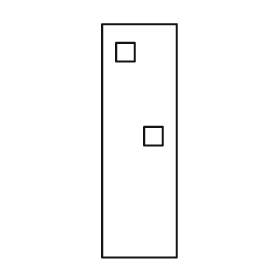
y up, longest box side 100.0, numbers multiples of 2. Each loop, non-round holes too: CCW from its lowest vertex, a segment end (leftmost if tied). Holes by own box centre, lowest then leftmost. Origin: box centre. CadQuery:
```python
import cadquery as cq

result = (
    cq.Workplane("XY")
    .moveTo(-16.0, -50.0)
    .lineTo(16.0, -50.0)
    .lineTo(16.0, 50.0)
    .lineTo(-16.0, 50.0)
    .close()
    .moveTo(2.0, -2.0)
    .lineTo(10.0, -2.0)
    .lineTo(10.0, 6.0)
    .lineTo(2.0, 6.0)
    .close()
    .moveTo(-10.0, 34.0)
    .lineTo(-2.0, 34.0)
    .lineTo(-2.0, 42.0)
    .lineTo(-10.0, 42.0)
    .close()
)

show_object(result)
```